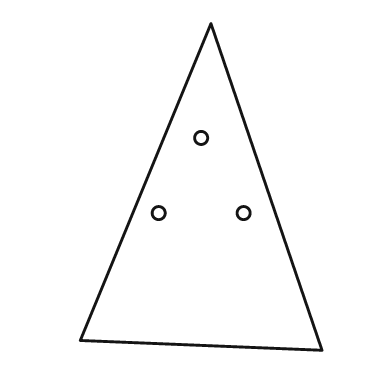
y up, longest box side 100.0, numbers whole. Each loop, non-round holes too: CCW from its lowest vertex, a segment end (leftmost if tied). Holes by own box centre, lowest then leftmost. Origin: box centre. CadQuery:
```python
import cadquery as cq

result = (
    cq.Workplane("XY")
    .moveTo(37.0, -50.0)
    .lineTo(3.0, 50.0)
    .lineTo(-37.0, -47.0)
    .close()
    .moveTo(-13.0, -8.0)
    .circle(2.0)
    .moveTo(13.0, -8.0)
    .circle(2.0)
    .moveTo(0.0, 15.0)
    .circle(2.0)
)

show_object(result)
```